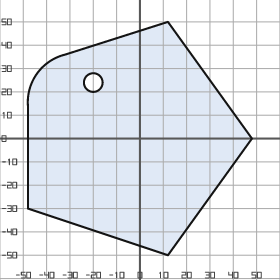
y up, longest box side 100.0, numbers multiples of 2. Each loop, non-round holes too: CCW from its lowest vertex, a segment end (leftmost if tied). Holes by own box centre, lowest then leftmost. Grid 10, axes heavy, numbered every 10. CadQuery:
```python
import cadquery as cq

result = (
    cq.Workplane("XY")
    .moveTo(12.0, -50.0)
    .lineTo(48.0, 0.0)
    .lineTo(12.0, 50.0)
    .lineTo(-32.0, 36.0)
    .threePointArc((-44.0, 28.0), (-48.0, 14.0))
    .lineTo(-48.0, -30.0)
    .close()
    .moveTo(-20.0, 24.0)
    .circle(4.0)
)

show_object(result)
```